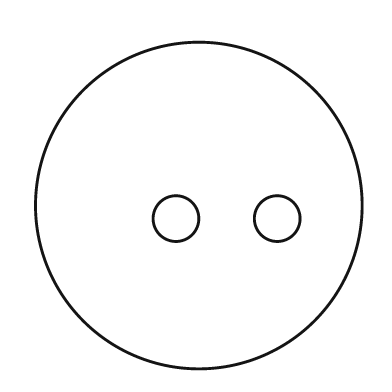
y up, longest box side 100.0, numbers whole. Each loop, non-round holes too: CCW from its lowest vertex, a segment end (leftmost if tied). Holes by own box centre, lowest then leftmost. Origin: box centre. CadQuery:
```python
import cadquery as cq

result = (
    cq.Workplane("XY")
    .moveTo(0.0, 0.0)
    .circle(50.0)
    .moveTo(-7.0, -4.0)
    .circle(7.0)
    .moveTo(24.0, -4.0)
    .circle(7.0)
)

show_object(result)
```